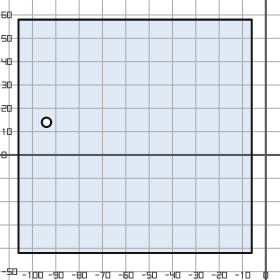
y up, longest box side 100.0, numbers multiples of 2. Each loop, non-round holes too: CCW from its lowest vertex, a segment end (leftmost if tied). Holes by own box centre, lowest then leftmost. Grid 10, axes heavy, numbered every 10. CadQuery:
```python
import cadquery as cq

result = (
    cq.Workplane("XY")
    .moveTo(-106.0, -42.0)
    .lineTo(-6.0, -42.0)
    .lineTo(-6.0, 58.0)
    .lineTo(-106.0, 58.0)
    .close()
    .moveTo(-94.0, 14.0)
    .circle(2.0)
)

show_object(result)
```